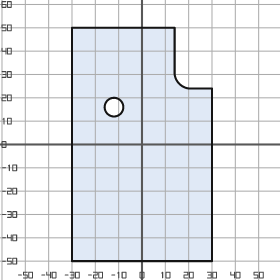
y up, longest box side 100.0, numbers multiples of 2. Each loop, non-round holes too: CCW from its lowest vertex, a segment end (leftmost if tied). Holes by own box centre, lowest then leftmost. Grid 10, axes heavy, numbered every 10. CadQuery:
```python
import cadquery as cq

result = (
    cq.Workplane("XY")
    .moveTo(-30.0, -50.0)
    .lineTo(30.0, -50.0)
    .lineTo(30.0, 24.0)
    .lineTo(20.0, 24.0)
    .threePointArc((16.0, 26.0), (14.0, 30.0))
    .lineTo(14.0, 50.0)
    .lineTo(-30.0, 50.0)
    .close()
    .moveTo(-12.0, 16.0)
    .circle(4.0)
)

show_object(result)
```